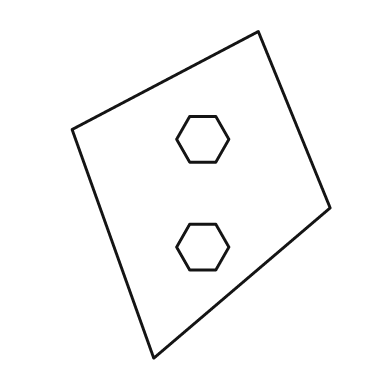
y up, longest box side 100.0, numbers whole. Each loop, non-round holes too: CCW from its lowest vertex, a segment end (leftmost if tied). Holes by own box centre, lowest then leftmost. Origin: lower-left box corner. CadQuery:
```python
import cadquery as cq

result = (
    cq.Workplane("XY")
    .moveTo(25.0, 0.0)
    .lineTo(79.0, 46.0)
    .lineTo(57.0, 100.0)
    .lineTo(0.0, 70.0)
    .close()
    .moveTo(36.0, 27.0)
    .lineTo(44.0, 27.0)
    .lineTo(48.0, 34.0)
    .lineTo(44.0, 41.0)
    .lineTo(36.0, 41.0)
    .lineTo(32.0, 34.0)
    .close()
    .moveTo(36.0, 60.0)
    .lineTo(44.0, 60.0)
    .lineTo(48.0, 67.0)
    .lineTo(44.0, 74.0)
    .lineTo(36.0, 74.0)
    .lineTo(32.0, 67.0)
    .close()
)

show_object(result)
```